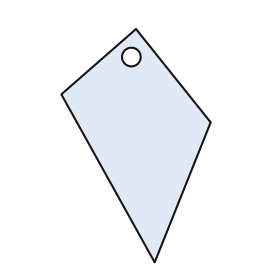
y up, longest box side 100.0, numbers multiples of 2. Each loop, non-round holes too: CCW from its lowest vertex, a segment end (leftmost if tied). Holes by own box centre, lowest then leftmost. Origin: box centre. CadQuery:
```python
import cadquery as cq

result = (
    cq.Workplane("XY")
    .moveTo(8.0, -50.0)
    .lineTo(32.0, 10.0)
    .lineTo(0.0, 50.0)
    .lineTo(-32.0, 22.0)
    .close()
    .moveTo(-2.0, 38.0)
    .circle(4.0)
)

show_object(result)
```